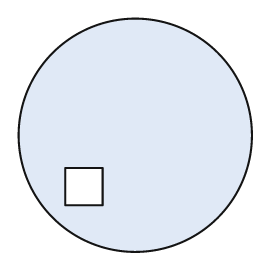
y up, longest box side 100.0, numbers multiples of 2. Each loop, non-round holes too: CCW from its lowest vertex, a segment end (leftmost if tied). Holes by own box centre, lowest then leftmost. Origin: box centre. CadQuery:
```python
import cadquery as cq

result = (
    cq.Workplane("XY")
    .moveTo(0.0, 0.0)
    .circle(50.0)
    .moveTo(-30.0, -30.0)
    .lineTo(-14.0, -30.0)
    .lineTo(-14.0, -14.0)
    .lineTo(-30.0, -14.0)
    .close()
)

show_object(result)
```